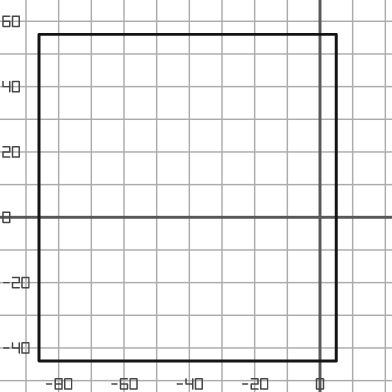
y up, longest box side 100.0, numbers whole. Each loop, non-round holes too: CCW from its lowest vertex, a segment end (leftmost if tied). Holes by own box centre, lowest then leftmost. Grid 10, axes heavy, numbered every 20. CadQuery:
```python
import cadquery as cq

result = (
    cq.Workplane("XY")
    .moveTo(-86.0, -44.0)
    .lineTo(5.0, -44.0)
    .lineTo(5.0, 56.0)
    .lineTo(-86.0, 56.0)
    .close()
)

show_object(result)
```